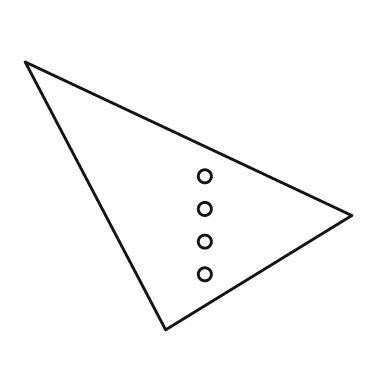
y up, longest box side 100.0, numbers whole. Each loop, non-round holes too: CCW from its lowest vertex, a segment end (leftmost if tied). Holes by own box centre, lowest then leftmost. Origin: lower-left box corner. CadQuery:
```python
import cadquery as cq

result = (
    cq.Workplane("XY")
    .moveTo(43.0, 0.0)
    .lineTo(100.0, 35.0)
    .lineTo(0.0, 82.0)
    .close()
    .moveTo(55.0, 17.0)
    .circle(2.0)
    .moveTo(55.0, 27.0)
    .circle(2.0)
    .moveTo(55.0, 37.0)
    .circle(2.0)
    .moveTo(55.0, 47.0)
    .circle(2.0)
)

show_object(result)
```